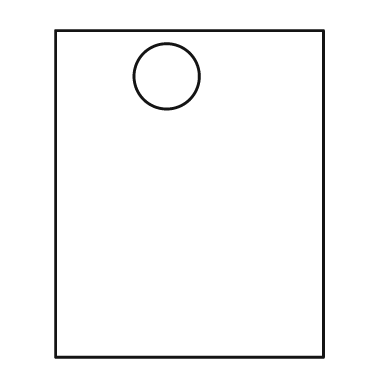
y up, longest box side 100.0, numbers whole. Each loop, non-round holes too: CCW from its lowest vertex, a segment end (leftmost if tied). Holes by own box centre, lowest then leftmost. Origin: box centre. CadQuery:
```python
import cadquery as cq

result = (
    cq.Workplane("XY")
    .moveTo(-41.0, -50.0)
    .lineTo(41.0, -50.0)
    .lineTo(41.0, 50.0)
    .lineTo(-41.0, 50.0)
    .close()
    .moveTo(-7.0, 36.0)
    .circle(10.0)
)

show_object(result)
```